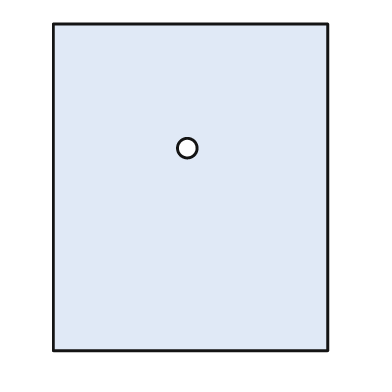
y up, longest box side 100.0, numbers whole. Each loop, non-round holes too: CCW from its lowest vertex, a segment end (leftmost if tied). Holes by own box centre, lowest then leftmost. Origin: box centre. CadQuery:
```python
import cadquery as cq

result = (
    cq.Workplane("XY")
    .moveTo(-42.0, -50.0)
    .lineTo(42.0, -50.0)
    .lineTo(42.0, 50.0)
    .lineTo(-42.0, 50.0)
    .close()
    .moveTo(-1.0, 12.0)
    .circle(3.0)
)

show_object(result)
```